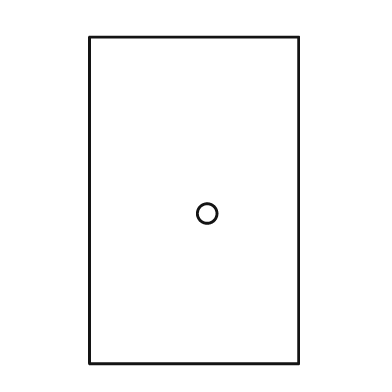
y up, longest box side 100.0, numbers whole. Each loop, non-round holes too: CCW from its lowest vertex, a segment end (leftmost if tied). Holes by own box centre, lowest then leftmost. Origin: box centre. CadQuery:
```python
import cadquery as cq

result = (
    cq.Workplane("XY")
    .moveTo(-32.0, -50.0)
    .lineTo(32.0, -50.0)
    .lineTo(32.0, 50.0)
    .lineTo(-32.0, 50.0)
    .close()
    .moveTo(4.0, -4.0)
    .circle(3.0)
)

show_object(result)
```